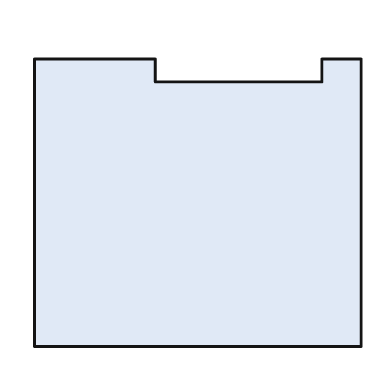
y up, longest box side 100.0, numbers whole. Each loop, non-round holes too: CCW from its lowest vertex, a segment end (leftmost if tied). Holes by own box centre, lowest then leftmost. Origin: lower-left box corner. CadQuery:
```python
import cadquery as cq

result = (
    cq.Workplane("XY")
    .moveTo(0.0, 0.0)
    .lineTo(100.0, 0.0)
    .lineTo(100.0, 88.0)
    .lineTo(88.0, 88.0)
    .lineTo(88.0, 81.0)
    .lineTo(37.0, 81.0)
    .lineTo(37.0, 88.0)
    .lineTo(0.0, 88.0)
    .close()
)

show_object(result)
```